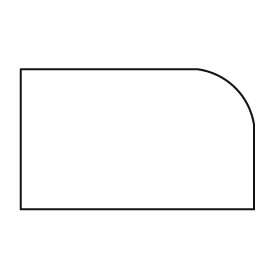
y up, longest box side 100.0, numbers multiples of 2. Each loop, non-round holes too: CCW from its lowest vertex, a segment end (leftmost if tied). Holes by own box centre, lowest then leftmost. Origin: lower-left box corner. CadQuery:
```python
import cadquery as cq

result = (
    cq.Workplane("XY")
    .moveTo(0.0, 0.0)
    .lineTo(100.0, 0.0)
    .lineTo(100.0, 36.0)
    .threePointArc((92.0, 52.0), (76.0, 60.0))
    .lineTo(0.0, 60.0)
    .close()
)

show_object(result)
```